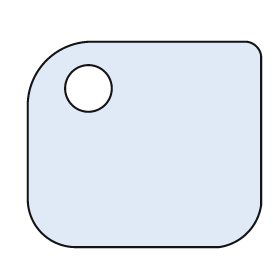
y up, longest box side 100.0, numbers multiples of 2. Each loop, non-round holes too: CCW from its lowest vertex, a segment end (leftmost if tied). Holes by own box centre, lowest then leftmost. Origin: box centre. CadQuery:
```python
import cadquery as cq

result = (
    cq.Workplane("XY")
    .moveTo(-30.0, -44.0)
    .lineTo(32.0, -44.0)
    .threePointArc((44.0, -38.0), (50.0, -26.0))
    .lineTo(50.0, 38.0)
    .threePointArc((48.0, 42.0), (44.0, 44.0))
    .lineTo(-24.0, 44.0)
    .threePointArc((-42.0, 36.0), (-50.0, 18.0))
    .lineTo(-50.0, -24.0)
    .threePointArc((-44.0, -38.0), (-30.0, -44.0))
    .close()
    .moveTo(-24.0, 24.0)
    .circle(10.0)
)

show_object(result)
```